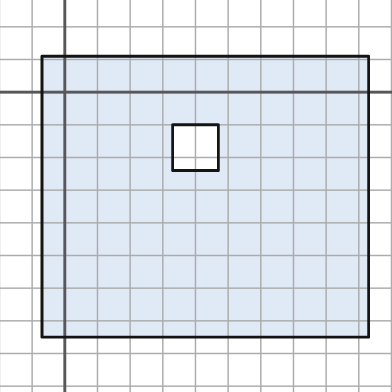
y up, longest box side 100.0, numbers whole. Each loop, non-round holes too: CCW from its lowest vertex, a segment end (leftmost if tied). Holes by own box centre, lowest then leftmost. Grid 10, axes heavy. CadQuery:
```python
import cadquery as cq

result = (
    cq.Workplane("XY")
    .moveTo(-7.0, -75.0)
    .lineTo(93.0, -75.0)
    .lineTo(93.0, 11.0)
    .lineTo(-7.0, 11.0)
    .close()
    .moveTo(33.0, -24.0)
    .lineTo(47.0, -24.0)
    .lineTo(47.0, -10.0)
    .lineTo(33.0, -10.0)
    .close()
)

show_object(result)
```